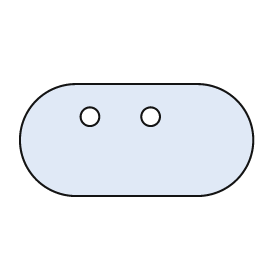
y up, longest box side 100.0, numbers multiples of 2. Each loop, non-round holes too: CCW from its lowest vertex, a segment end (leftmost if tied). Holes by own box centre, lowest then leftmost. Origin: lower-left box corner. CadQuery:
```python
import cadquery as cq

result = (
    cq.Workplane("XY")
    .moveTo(24.0, 0.0)
    .lineTo(76.0, 0.0)
    .threePointArc((100.0, 24.0), (76.0, 48.0))
    .lineTo(24.0, 48.0)
    .threePointArc((0.0, 24.0), (24.0, 0.0))
    .close()
    .moveTo(30.0, 34.0)
    .circle(4.0)
    .moveTo(56.0, 34.0)
    .circle(4.0)
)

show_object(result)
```